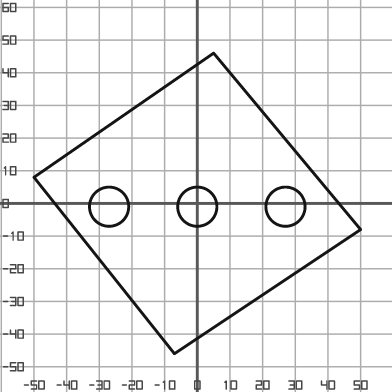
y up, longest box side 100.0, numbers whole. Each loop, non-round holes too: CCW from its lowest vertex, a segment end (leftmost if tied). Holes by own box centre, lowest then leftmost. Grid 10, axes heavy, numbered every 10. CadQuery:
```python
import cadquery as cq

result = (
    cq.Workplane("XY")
    .moveTo(-7.0, -46.0)
    .lineTo(50.0, -8.0)
    .lineTo(5.0, 46.0)
    .lineTo(-50.0, 8.0)
    .close()
    .moveTo(-27.0, -1.0)
    .circle(6.0)
    .moveTo(0.0, -1.0)
    .circle(6.0)
    .moveTo(27.0, -1.0)
    .circle(6.0)
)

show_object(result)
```